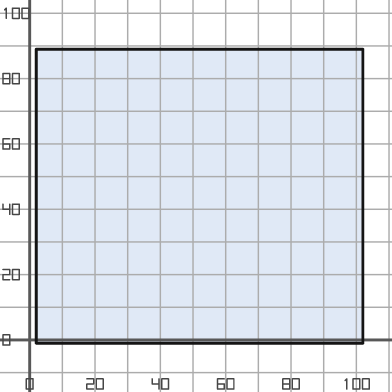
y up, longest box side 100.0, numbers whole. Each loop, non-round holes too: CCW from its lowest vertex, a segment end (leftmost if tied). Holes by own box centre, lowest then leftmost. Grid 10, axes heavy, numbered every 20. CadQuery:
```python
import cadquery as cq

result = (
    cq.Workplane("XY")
    .moveTo(2.0, -1.0)
    .lineTo(102.0, -1.0)
    .lineTo(102.0, 89.0)
    .lineTo(2.0, 89.0)
    .close()
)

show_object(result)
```